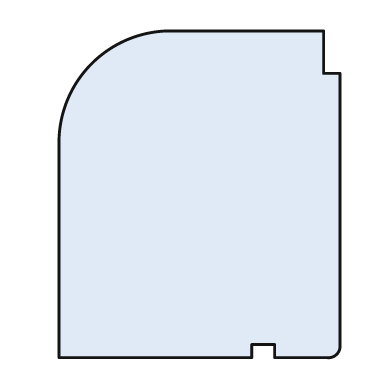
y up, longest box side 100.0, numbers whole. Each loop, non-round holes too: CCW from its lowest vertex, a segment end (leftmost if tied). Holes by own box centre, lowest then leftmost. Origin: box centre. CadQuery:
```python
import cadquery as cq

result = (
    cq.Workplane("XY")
    .moveTo(-43.0, -50.0)
    .lineTo(16.0, -50.0)
    .lineTo(16.0, -46.0)
    .lineTo(23.0, -46.0)
    .lineTo(23.0, -50.0)
    .lineTo(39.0, -50.0)
    .threePointArc((42.0, -49.0), (43.0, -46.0))
    .lineTo(43.0, 37.0)
    .lineTo(38.0, 37.0)
    .lineTo(38.0, 50.0)
    .lineTo(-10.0, 50.0)
    .threePointArc((-33.0, 40.0), (-43.0, 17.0))
    .close()
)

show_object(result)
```